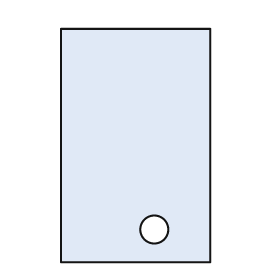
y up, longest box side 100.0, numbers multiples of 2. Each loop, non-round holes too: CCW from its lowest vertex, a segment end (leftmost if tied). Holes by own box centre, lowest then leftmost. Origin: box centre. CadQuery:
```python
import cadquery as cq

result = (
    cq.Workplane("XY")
    .moveTo(-32.0, -50.0)
    .lineTo(32.0, -50.0)
    .lineTo(32.0, 50.0)
    .lineTo(-32.0, 50.0)
    .close()
    .moveTo(8.0, -36.0)
    .circle(6.0)
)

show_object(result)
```